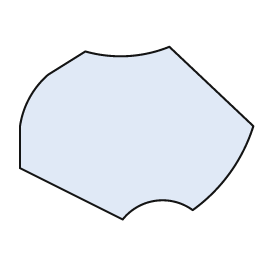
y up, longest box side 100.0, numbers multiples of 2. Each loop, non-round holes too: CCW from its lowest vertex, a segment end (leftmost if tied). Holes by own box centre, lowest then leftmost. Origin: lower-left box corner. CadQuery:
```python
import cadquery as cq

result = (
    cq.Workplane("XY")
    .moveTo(44.0, 0.0)
    .threePointArc((58.0, 8.0), (74.0, 4.0))
    .threePointArc((90.0, 20.0), (100.0, 40.0))
    .lineTo(64.0, 74.0)
    .threePointArc((46.0, 70.0), (28.0, 72.0))
    .lineTo(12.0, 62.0)
    .threePointArc((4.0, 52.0), (0.0, 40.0))
    .lineTo(0.0, 22.0)
    .close()
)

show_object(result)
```